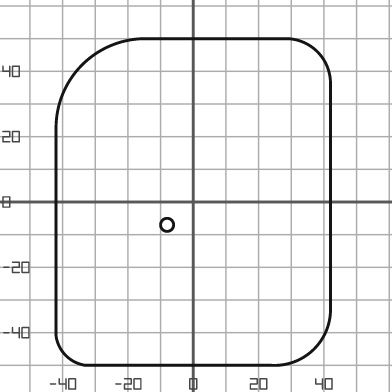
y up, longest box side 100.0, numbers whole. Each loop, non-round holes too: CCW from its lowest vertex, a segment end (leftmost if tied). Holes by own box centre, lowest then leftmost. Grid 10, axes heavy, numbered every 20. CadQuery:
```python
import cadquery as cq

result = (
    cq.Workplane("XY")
    .moveTo(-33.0, -50.0)
    .lineTo(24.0, -50.0)
    .threePointArc((37.0, -45.0), (42.0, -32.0))
    .lineTo(42.0, 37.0)
    .threePointArc((38.0, 46.0), (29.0, 50.0))
    .lineTo(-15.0, 50.0)
    .threePointArc((-34.0, 42.0), (-42.0, 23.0))
    .lineTo(-42.0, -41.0)
    .threePointArc((-39.0, -47.0), (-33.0, -50.0))
    .close()
    .moveTo(-8.0, -7.0)
    .circle(2.0)
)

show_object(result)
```